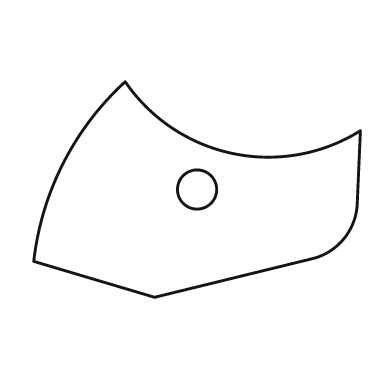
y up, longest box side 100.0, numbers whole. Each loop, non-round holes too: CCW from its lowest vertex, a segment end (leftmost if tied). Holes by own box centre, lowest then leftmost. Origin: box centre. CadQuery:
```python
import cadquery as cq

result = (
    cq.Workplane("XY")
    .moveTo(-13.0, -33.0)
    .lineTo(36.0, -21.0)
    .threePointArc((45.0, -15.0), (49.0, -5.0))
    .lineTo(50.0, 18.0)
    .threePointArc((11.0, 11.0), (-22.0, 33.0))
    .threePointArc((-41.0, 8.0), (-50.0, -22.0))
    .close()
    .moveTo(0.0, 0.0)
    .circle(6.0)
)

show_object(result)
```